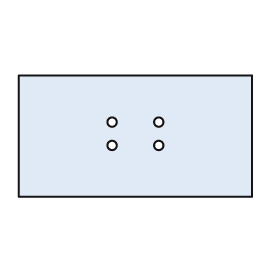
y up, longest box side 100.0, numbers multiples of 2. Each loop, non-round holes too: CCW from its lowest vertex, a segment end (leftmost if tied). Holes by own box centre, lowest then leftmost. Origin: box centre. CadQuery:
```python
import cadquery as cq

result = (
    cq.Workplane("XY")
    .moveTo(-50.0, -26.0)
    .lineTo(50.0, -26.0)
    .lineTo(50.0, 26.0)
    .lineTo(-50.0, 26.0)
    .close()
    .moveTo(-10.0, -4.0)
    .circle(2.0)
    .moveTo(10.0, -4.0)
    .circle(2.0)
    .moveTo(-10.0, 6.0)
    .circle(2.0)
    .moveTo(10.0, 6.0)
    .circle(2.0)
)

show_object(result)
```